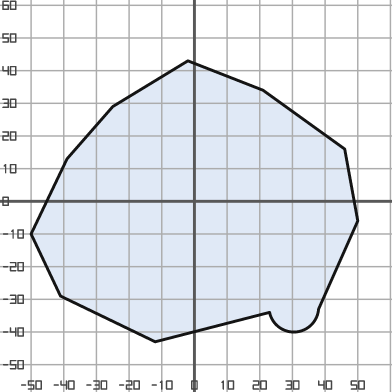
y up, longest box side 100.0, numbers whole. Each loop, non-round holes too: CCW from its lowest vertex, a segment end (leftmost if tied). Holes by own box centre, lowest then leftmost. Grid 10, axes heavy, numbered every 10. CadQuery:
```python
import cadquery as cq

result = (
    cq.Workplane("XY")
    .moveTo(-12.0, -43.0)
    .lineTo(23.0, -34.0)
    .threePointArc((31.0, -40.0), (38.0, -33.0))
    .lineTo(50.0, -6.0)
    .lineTo(46.0, 16.0)
    .lineTo(21.0, 34.0)
    .lineTo(-2.0, 43.0)
    .lineTo(-25.0, 29.0)
    .lineTo(-39.0, 13.0)
    .lineTo(-50.0, -10.0)
    .lineTo(-41.0, -29.0)
    .close()
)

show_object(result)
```